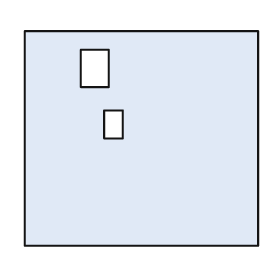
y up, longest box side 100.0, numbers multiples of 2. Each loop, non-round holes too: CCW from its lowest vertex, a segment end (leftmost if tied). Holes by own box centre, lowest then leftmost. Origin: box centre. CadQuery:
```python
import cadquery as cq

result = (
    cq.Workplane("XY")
    .moveTo(-50.0, -46.0)
    .lineTo(50.0, -46.0)
    .lineTo(50.0, 46.0)
    .lineTo(-50.0, 46.0)
    .close()
    .moveTo(-16.0, 0.0)
    .lineTo(-8.0, 0.0)
    .lineTo(-8.0, 12.0)
    .lineTo(-16.0, 12.0)
    .close()
    .moveTo(-26.0, 22.0)
    .lineTo(-14.0, 22.0)
    .lineTo(-14.0, 38.0)
    .lineTo(-26.0, 38.0)
    .close()
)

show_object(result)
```